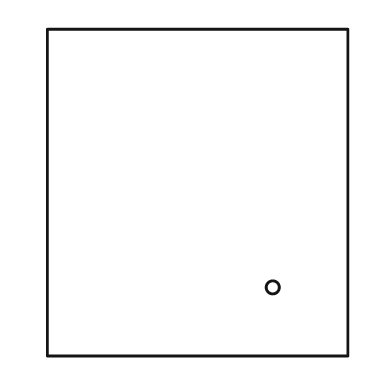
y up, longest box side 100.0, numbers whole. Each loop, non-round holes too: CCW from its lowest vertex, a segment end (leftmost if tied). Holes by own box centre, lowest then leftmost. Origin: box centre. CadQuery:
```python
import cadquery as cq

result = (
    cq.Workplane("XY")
    .moveTo(-46.0, -50.0)
    .lineTo(46.0, -50.0)
    .lineTo(46.0, 50.0)
    .lineTo(-46.0, 50.0)
    .close()
    .moveTo(23.0, -29.0)
    .circle(2.0)
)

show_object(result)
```